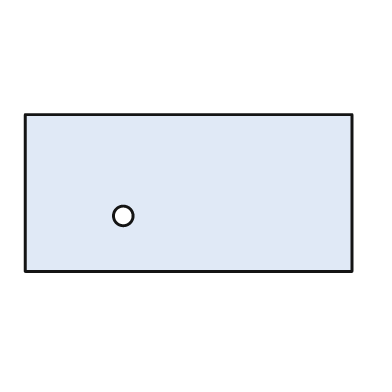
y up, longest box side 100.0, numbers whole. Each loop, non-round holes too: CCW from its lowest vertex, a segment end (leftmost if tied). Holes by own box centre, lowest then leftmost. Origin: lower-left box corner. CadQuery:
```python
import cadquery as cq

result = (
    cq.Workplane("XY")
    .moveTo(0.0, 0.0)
    .lineTo(100.0, 0.0)
    .lineTo(100.0, 48.0)
    .lineTo(0.0, 48.0)
    .close()
    .moveTo(30.0, 17.0)
    .circle(3.0)
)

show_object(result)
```